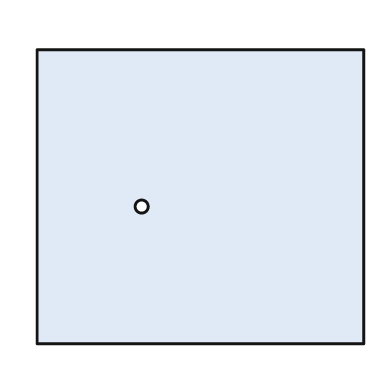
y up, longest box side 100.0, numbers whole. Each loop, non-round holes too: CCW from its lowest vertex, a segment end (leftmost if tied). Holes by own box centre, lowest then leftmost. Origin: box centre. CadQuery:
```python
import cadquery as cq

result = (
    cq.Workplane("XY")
    .moveTo(-50.0, -45.0)
    .lineTo(50.0, -45.0)
    .lineTo(50.0, 45.0)
    .lineTo(-50.0, 45.0)
    .close()
    .moveTo(-18.0, -3.0)
    .circle(2.0)
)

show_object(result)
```